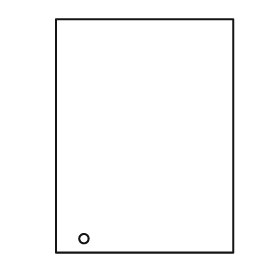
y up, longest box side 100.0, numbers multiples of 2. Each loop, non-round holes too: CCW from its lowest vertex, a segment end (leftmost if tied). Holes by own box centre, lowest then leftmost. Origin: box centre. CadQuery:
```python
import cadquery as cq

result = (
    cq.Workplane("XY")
    .moveTo(-38.0, -50.0)
    .lineTo(38.0, -50.0)
    .lineTo(38.0, 50.0)
    .lineTo(-38.0, 50.0)
    .close()
    .moveTo(-26.0, -44.0)
    .circle(2.0)
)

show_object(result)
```